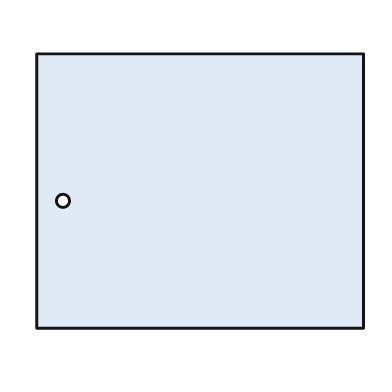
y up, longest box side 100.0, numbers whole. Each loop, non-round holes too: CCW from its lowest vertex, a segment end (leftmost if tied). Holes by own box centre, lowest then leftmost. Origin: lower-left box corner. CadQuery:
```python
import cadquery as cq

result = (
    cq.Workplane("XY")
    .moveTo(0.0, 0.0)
    .lineTo(100.0, 0.0)
    .lineTo(100.0, 84.0)
    .lineTo(0.0, 84.0)
    .close()
    .moveTo(8.0, 39.0)
    .circle(2.0)
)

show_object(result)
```